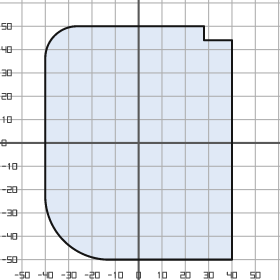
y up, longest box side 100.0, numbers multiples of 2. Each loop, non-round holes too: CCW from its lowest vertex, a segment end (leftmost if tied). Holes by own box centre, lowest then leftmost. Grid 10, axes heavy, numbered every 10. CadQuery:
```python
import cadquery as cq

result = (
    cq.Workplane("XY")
    .moveTo(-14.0, -50.0)
    .lineTo(40.0, -50.0)
    .lineTo(40.0, 44.0)
    .lineTo(28.0, 44.0)
    .lineTo(28.0, 50.0)
    .lineTo(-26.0, 50.0)
    .threePointArc((-36.0, 46.0), (-40.0, 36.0))
    .lineTo(-40.0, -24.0)
    .threePointArc((-32.0, -42.0), (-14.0, -50.0))
    .close()
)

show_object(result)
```